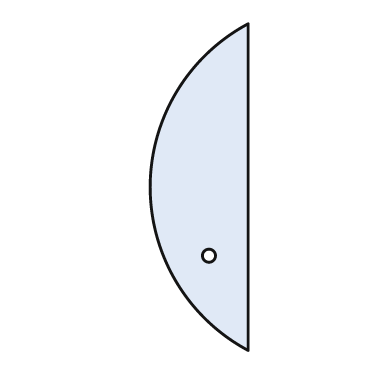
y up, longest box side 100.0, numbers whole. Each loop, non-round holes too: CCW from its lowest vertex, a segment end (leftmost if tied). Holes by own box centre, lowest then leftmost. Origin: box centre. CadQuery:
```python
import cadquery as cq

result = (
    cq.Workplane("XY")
    .moveTo(15.0, -50.0)
    .lineTo(15.0, 50.0)
    .threePointArc((-15.0, 0.0), (15.0, -50.0))
    .close()
    .moveTo(3.0, -21.0)
    .circle(2.0)
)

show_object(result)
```